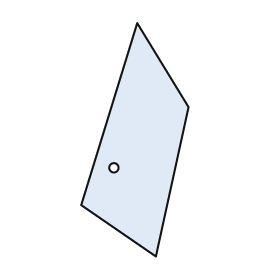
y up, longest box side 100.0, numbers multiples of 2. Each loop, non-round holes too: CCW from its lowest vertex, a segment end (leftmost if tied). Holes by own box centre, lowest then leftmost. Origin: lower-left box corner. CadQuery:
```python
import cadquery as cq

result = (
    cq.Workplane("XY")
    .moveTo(32.0, 0.0)
    .lineTo(46.0, 64.0)
    .lineTo(24.0, 100.0)
    .lineTo(0.0, 22.0)
    .close()
    .moveTo(14.0, 38.0)
    .circle(2.0)
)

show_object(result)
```